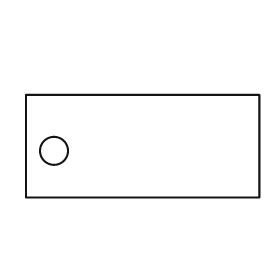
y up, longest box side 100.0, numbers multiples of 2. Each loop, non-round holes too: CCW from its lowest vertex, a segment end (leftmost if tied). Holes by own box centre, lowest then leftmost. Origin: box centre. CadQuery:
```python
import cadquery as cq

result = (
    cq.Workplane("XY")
    .moveTo(-50.0, -22.0)
    .lineTo(50.0, -22.0)
    .lineTo(50.0, 22.0)
    .lineTo(-50.0, 22.0)
    .close()
    .moveTo(-38.0, -2.0)
    .circle(6.0)
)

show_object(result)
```